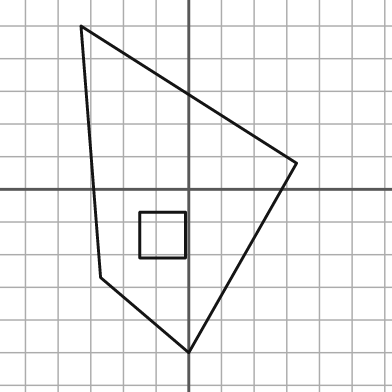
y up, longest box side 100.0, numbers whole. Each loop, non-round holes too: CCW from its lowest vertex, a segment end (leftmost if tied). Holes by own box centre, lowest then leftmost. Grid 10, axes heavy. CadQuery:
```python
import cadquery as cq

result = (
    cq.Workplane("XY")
    .moveTo(0.0, -50.0)
    .lineTo(33.0, 8.0)
    .lineTo(-33.0, 50.0)
    .lineTo(-27.0, -27.0)
    .close()
    .moveTo(-15.0, -21.0)
    .lineTo(-1.0, -21.0)
    .lineTo(-1.0, -7.0)
    .lineTo(-15.0, -7.0)
    .close()
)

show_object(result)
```